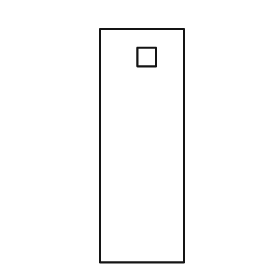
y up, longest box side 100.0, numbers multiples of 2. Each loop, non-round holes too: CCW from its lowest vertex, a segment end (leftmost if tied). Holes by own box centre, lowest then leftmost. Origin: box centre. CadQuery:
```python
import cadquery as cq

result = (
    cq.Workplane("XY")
    .moveTo(-18.0, -50.0)
    .lineTo(18.0, -50.0)
    .lineTo(18.0, 50.0)
    .lineTo(-18.0, 50.0)
    .close()
    .moveTo(-2.0, 34.0)
    .lineTo(6.0, 34.0)
    .lineTo(6.0, 42.0)
    .lineTo(-2.0, 42.0)
    .close()
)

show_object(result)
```